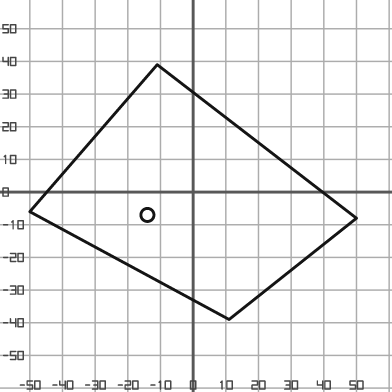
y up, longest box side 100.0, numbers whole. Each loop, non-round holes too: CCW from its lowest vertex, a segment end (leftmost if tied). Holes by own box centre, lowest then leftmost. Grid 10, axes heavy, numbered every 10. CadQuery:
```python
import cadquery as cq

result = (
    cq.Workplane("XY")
    .moveTo(11.0, -39.0)
    .lineTo(50.0, -8.0)
    .lineTo(-11.0, 39.0)
    .lineTo(-50.0, -6.0)
    .close()
    .moveTo(-14.0, -7.0)
    .circle(2.0)
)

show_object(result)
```